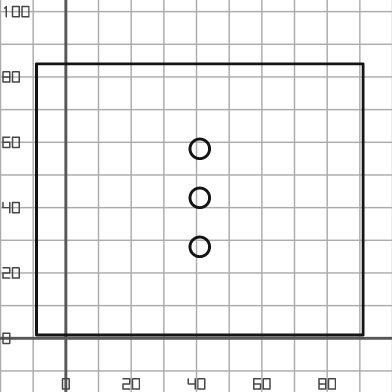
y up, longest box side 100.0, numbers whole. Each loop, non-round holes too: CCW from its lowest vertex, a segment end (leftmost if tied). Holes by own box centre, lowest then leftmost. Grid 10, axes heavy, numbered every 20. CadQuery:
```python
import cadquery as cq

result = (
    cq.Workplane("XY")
    .moveTo(-9.0, 1.0)
    .lineTo(91.0, 1.0)
    .lineTo(91.0, 84.0)
    .lineTo(-9.0, 84.0)
    .close()
    .moveTo(41.0, 28.0)
    .circle(3.0)
    .moveTo(41.0, 43.0)
    .circle(3.0)
    .moveTo(41.0, 58.0)
    .circle(3.0)
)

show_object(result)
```